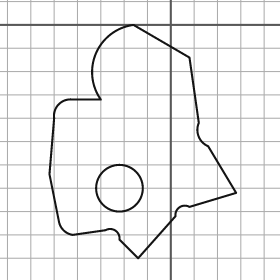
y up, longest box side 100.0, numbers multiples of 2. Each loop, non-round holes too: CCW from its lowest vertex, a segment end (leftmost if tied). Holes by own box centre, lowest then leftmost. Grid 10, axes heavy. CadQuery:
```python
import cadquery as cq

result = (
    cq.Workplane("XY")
    .moveTo(-14.0, -100.0)
    .lineTo(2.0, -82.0)
    .threePointArc((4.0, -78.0), (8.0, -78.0))
    .lineTo(28.0, -72.0)
    .lineTo(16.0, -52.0)
    .threePointArc((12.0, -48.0), (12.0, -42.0))
    .lineTo(8.0, -14.0)
    .lineTo(-16.0, 0.0)
    .threePointArc((-32.0, -12.0), (-30.0, -32.0))
    .lineTo(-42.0, -32.0)
    .threePointArc((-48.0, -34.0), (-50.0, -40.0))
    .lineTo(-52.0, -64.0)
    .lineTo(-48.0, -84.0)
    .threePointArc((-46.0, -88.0), (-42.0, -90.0))
    .lineTo(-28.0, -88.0)
    .threePointArc((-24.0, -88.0), (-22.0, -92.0))
    .close()
    .moveTo(-22.0, -70.0)
    .circle(10.0)
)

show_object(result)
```